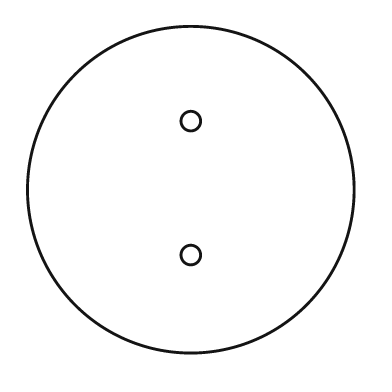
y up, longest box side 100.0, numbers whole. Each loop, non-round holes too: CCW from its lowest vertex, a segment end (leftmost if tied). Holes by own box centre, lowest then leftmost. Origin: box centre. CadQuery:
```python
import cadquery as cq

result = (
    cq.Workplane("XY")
    .moveTo(0.0, 0.0)
    .circle(50.0)
    .moveTo(0.0, -20.0)
    .circle(3.0)
    .moveTo(0.0, 21.0)
    .circle(3.0)
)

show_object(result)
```